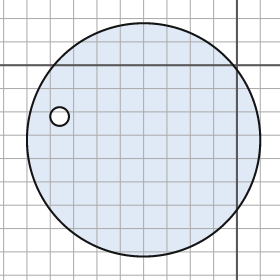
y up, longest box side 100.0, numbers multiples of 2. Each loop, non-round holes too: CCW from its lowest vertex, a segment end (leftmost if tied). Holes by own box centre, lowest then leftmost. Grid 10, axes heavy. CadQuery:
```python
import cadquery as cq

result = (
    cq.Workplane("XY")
    .moveTo(-40.0, -32.0)
    .circle(50.0)
    .moveTo(-76.0, -22.0)
    .circle(4.0)
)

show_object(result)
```